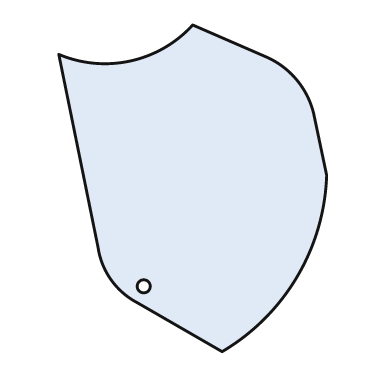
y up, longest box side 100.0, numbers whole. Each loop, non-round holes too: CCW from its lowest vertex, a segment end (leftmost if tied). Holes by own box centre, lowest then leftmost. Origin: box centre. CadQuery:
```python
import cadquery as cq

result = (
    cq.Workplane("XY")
    .moveTo(9.0, -50.0)
    .threePointArc((32.0, -27.0), (41.0, 4.0))
    .lineTo(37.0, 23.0)
    .threePointArc((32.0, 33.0), (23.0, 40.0))
    .lineTo(0.0, 50.0)
    .threePointArc((-19.0, 39.0), (-41.0, 41.0))
    .lineTo(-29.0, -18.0)
    .threePointArc((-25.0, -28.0), (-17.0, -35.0))
    .close()
    .moveTo(-15.0, -30.0)
    .circle(2.0)
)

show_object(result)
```